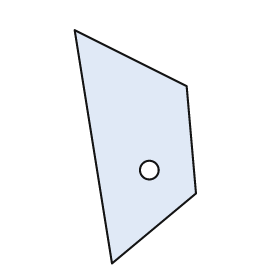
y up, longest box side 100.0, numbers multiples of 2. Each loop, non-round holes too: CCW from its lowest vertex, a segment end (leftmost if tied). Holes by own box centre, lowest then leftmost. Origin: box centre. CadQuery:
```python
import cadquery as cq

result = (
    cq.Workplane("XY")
    .moveTo(-10.0, -50.0)
    .lineTo(26.0, -20.0)
    .lineTo(22.0, 26.0)
    .lineTo(-26.0, 50.0)
    .close()
    .moveTo(6.0, -10.0)
    .circle(4.0)
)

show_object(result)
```